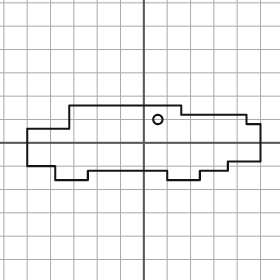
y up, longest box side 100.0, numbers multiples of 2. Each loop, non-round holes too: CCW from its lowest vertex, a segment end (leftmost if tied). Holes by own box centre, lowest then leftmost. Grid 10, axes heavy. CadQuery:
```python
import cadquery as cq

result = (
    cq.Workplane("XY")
    .moveTo(-38.0, -16.0)
    .lineTo(-24.0, -16.0)
    .lineTo(-24.0, -12.0)
    .lineTo(10.0, -12.0)
    .lineTo(10.0, -16.0)
    .lineTo(24.0, -16.0)
    .lineTo(24.0, -12.0)
    .lineTo(36.0, -12.0)
    .lineTo(36.0, -8.0)
    .lineTo(50.0, -8.0)
    .lineTo(50.0, 8.0)
    .lineTo(44.0, 8.0)
    .lineTo(44.0, 12.0)
    .lineTo(16.0, 12.0)
    .lineTo(16.0, 16.0)
    .lineTo(-32.0, 16.0)
    .lineTo(-32.0, 6.0)
    .lineTo(-50.0, 6.0)
    .lineTo(-50.0, -10.0)
    .lineTo(-38.0, -10.0)
    .close()
    .moveTo(6.0, 10.0)
    .circle(2.0)
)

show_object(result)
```